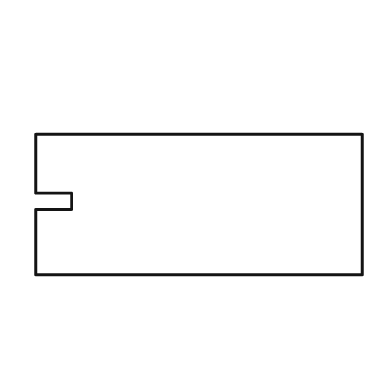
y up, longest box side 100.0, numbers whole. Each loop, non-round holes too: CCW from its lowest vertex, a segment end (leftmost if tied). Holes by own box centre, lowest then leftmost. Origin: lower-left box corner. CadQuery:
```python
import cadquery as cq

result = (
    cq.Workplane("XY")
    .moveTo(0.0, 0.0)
    .lineTo(100.0, 0.0)
    .lineTo(100.0, 43.0)
    .lineTo(0.0, 43.0)
    .lineTo(0.0, 25.0)
    .lineTo(11.0, 25.0)
    .lineTo(11.0, 20.0)
    .lineTo(0.0, 20.0)
    .close()
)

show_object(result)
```